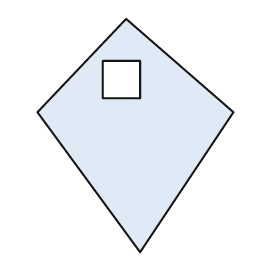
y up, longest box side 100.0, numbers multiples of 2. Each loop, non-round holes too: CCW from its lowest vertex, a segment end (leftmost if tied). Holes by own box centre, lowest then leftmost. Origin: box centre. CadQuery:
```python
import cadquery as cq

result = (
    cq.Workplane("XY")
    .moveTo(2.0, -50.0)
    .lineTo(42.0, 10.0)
    .lineTo(-4.0, 50.0)
    .lineTo(-42.0, 10.0)
    .close()
    .moveTo(-14.0, 16.0)
    .lineTo(2.0, 16.0)
    .lineTo(2.0, 32.0)
    .lineTo(-14.0, 32.0)
    .close()
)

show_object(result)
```